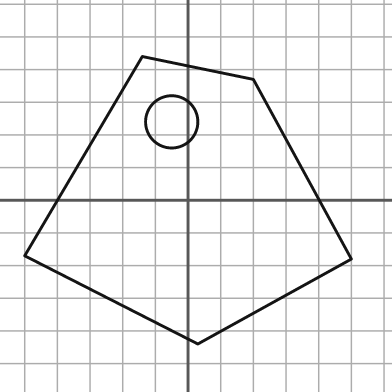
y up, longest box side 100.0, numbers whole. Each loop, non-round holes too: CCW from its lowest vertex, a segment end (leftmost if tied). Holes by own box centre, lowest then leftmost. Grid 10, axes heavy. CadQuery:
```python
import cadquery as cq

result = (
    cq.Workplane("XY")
    .moveTo(3.0, -44.0)
    .lineTo(50.0, -18.0)
    .lineTo(20.0, 37.0)
    .lineTo(-14.0, 44.0)
    .lineTo(-50.0, -17.0)
    .close()
    .moveTo(-5.0, 24.0)
    .circle(8.0)
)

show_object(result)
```